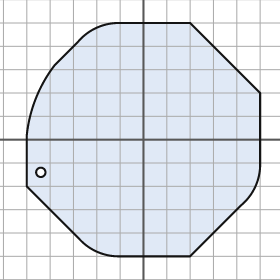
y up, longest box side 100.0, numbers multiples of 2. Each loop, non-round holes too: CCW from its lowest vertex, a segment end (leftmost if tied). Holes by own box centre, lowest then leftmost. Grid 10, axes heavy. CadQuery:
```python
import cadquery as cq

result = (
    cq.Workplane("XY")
    .moveTo(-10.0, -50.0)
    .lineTo(20.0, -50.0)
    .lineTo(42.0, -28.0)
    .threePointArc((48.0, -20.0), (50.0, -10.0))
    .lineTo(50.0, 20.0)
    .lineTo(20.0, 50.0)
    .lineTo(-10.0, 50.0)
    .threePointArc((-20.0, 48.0), (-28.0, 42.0))
    .lineTo(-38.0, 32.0)
    .threePointArc((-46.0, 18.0), (-50.0, 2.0))
    .lineTo(-50.0, -20.0)
    .lineTo(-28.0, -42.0)
    .threePointArc((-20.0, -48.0), (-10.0, -50.0))
    .close()
    .moveTo(-44.0, -14.0)
    .circle(2.0)
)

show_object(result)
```